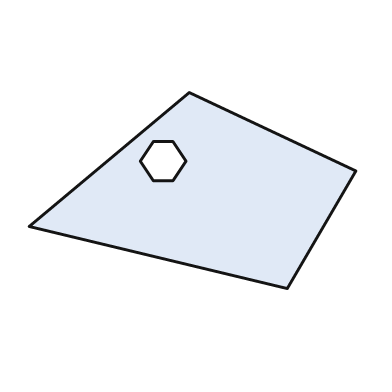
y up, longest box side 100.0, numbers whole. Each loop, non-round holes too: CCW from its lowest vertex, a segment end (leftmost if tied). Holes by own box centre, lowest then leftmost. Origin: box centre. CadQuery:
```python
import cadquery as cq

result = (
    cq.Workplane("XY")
    .moveTo(29.0, -30.0)
    .lineTo(50.0, 6.0)
    .lineTo(-1.0, 30.0)
    .lineTo(-50.0, -11.0)
    .close()
    .moveTo(-12.0, 3.0)
    .lineTo(-6.0, 3.0)
    .lineTo(-2.0, 9.0)
    .lineTo(-6.0, 15.0)
    .lineTo(-12.0, 15.0)
    .lineTo(-16.0, 9.0)
    .close()
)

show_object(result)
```